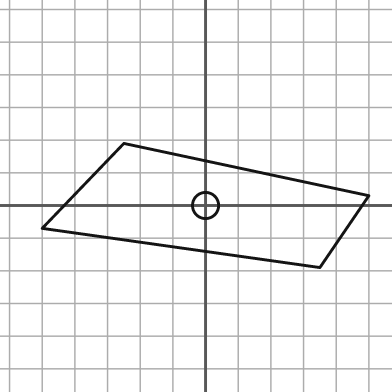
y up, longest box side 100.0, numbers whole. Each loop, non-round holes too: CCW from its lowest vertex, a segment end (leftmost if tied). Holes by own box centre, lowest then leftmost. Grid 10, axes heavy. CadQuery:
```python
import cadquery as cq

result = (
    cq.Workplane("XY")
    .moveTo(35.0, -19.0)
    .lineTo(50.0, 3.0)
    .lineTo(-25.0, 19.0)
    .lineTo(-50.0, -7.0)
    .close()
    .moveTo(0.0, 0.0)
    .circle(4.0)
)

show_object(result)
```